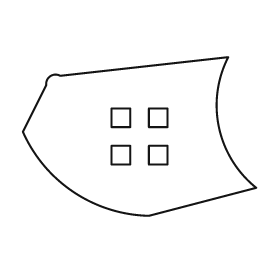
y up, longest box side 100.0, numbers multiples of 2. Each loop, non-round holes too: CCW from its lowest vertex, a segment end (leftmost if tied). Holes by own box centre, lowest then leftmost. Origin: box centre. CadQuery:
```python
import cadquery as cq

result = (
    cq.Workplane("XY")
    .moveTo(4.0, -34.0)
    .lineTo(50.0, -22.0)
    .threePointArc((34.0, 4.0), (38.0, 34.0))
    .lineTo(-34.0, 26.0)
    .threePointArc((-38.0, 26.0), (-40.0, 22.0))
    .lineTo(-50.0, 2.0)
    .threePointArc((-28.0, -24.0), (4.0, -34.0))
    .close()
    .moveTo(-12.0, -12.0)
    .lineTo(-4.0, -12.0)
    .lineTo(-4.0, -4.0)
    .lineTo(-12.0, -4.0)
    .close()
    .moveTo(4.0, -12.0)
    .lineTo(12.0, -12.0)
    .lineTo(12.0, -4.0)
    .lineTo(4.0, -4.0)
    .close()
    .moveTo(-12.0, 4.0)
    .lineTo(-4.0, 4.0)
    .lineTo(-4.0, 12.0)
    .lineTo(-12.0, 12.0)
    .close()
    .moveTo(4.0, 4.0)
    .lineTo(12.0, 4.0)
    .lineTo(12.0, 12.0)
    .lineTo(4.0, 12.0)
    .close()
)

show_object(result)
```